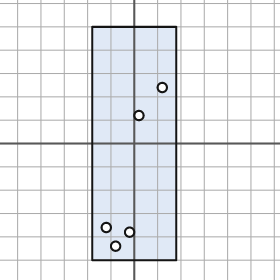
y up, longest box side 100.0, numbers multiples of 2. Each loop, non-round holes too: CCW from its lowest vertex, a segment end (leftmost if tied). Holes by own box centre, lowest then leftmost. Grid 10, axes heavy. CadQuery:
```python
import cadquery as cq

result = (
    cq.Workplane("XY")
    .moveTo(-18.0, -50.0)
    .lineTo(18.0, -50.0)
    .lineTo(18.0, 50.0)
    .lineTo(-18.0, 50.0)
    .close()
    .moveTo(-8.0, -44.0)
    .circle(2.0)
    .moveTo(-2.0, -38.0)
    .circle(2.0)
    .moveTo(-12.0, -36.0)
    .circle(2.0)
    .moveTo(2.0, 12.0)
    .circle(2.0)
    .moveTo(12.0, 24.0)
    .circle(2.0)
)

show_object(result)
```